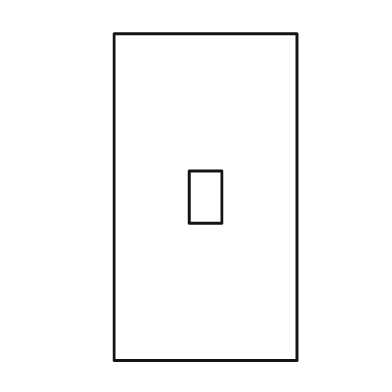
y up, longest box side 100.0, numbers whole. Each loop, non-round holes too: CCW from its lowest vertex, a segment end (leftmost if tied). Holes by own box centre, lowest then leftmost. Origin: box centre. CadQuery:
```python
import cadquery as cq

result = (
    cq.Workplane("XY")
    .moveTo(-28.0, -50.0)
    .lineTo(28.0, -50.0)
    .lineTo(28.0, 50.0)
    .lineTo(-28.0, 50.0)
    .close()
    .moveTo(-5.0, -8.0)
    .lineTo(5.0, -8.0)
    .lineTo(5.0, 8.0)
    .lineTo(-5.0, 8.0)
    .close()
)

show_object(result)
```